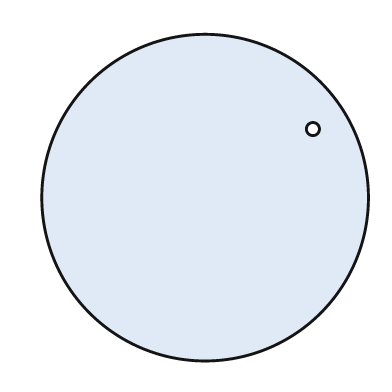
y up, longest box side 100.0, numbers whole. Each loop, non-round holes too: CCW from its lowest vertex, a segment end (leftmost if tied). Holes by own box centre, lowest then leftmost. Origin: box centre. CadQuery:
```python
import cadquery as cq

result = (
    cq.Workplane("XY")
    .moveTo(0.0, 0.0)
    .circle(50.0)
    .moveTo(33.0, 21.0)
    .circle(2.0)
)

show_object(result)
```